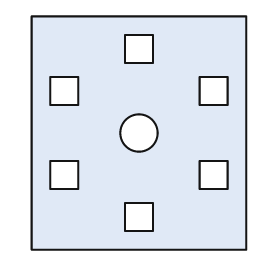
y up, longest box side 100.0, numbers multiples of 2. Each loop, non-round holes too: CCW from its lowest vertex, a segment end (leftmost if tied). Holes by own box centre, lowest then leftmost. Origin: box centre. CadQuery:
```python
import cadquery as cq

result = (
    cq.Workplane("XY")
    .moveTo(-46.0, -50.0)
    .lineTo(46.0, -50.0)
    .lineTo(46.0, 50.0)
    .lineTo(-46.0, 50.0)
    .close()
    .moveTo(-6.0, -42.0)
    .lineTo(6.0, -42.0)
    .lineTo(6.0, -30.0)
    .lineTo(-6.0, -30.0)
    .close()
    .moveTo(-38.0, -24.0)
    .lineTo(-26.0, -24.0)
    .lineTo(-26.0, -12.0)
    .lineTo(-38.0, -12.0)
    .close()
    .moveTo(26.0, -24.0)
    .lineTo(38.0, -24.0)
    .lineTo(38.0, -12.0)
    .lineTo(26.0, -12.0)
    .close()
    .moveTo(0.0, 0.0)
    .circle(8.0)
    .moveTo(-38.0, 12.0)
    .lineTo(-26.0, 12.0)
    .lineTo(-26.0, 24.0)
    .lineTo(-38.0, 24.0)
    .close()
    .moveTo(26.0, 12.0)
    .lineTo(38.0, 12.0)
    .lineTo(38.0, 24.0)
    .lineTo(26.0, 24.0)
    .close()
    .moveTo(-6.0, 30.0)
    .lineTo(6.0, 30.0)
    .lineTo(6.0, 42.0)
    .lineTo(-6.0, 42.0)
    .close()
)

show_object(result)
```